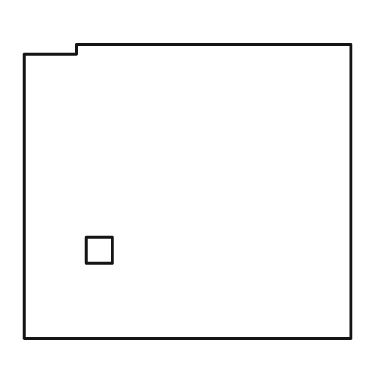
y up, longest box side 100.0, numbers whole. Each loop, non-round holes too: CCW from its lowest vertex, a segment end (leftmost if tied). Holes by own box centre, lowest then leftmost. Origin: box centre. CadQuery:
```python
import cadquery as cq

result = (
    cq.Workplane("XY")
    .moveTo(-50.0, -45.0)
    .lineTo(50.0, -45.0)
    .lineTo(50.0, 45.0)
    .lineTo(-34.0, 45.0)
    .lineTo(-34.0, 42.0)
    .lineTo(-50.0, 42.0)
    .close()
    .moveTo(-31.0, -22.0)
    .lineTo(-23.0, -22.0)
    .lineTo(-23.0, -14.0)
    .lineTo(-31.0, -14.0)
    .close()
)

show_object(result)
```